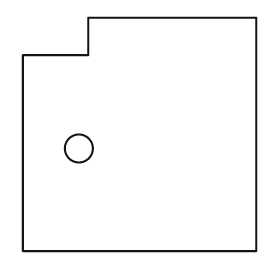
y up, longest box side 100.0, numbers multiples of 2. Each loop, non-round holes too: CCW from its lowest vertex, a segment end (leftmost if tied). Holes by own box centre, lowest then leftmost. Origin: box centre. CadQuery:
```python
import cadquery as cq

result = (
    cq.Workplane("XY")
    .moveTo(-50.0, -50.0)
    .lineTo(50.0, -50.0)
    .lineTo(50.0, 50.0)
    .lineTo(-22.0, 50.0)
    .lineTo(-22.0, 34.0)
    .lineTo(-50.0, 34.0)
    .close()
    .moveTo(-26.0, -6.0)
    .circle(6.0)
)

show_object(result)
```